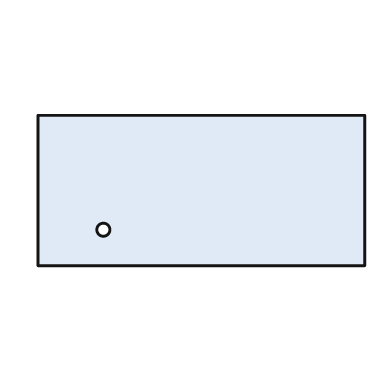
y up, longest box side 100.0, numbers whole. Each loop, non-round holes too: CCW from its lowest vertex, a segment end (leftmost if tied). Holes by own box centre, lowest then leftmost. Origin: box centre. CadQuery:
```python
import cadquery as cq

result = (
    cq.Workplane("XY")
    .moveTo(-50.0, -23.0)
    .lineTo(50.0, -23.0)
    .lineTo(50.0, 23.0)
    .lineTo(-50.0, 23.0)
    .close()
    .moveTo(-30.0, -12.0)
    .circle(2.0)
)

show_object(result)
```